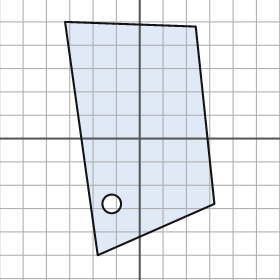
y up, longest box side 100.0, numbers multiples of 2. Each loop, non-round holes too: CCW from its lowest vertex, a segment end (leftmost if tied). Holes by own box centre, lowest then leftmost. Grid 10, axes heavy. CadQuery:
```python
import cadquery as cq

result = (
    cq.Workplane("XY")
    .moveTo(-18.0, -50.0)
    .lineTo(32.0, -28.0)
    .lineTo(24.0, 48.0)
    .lineTo(-32.0, 50.0)
    .close()
    .moveTo(-12.0, -28.0)
    .circle(4.0)
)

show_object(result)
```